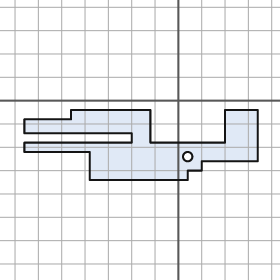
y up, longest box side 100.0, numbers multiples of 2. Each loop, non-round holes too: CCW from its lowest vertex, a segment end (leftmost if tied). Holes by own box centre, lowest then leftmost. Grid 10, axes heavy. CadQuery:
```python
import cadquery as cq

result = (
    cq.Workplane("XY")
    .moveTo(-38.0, -34.0)
    .lineTo(4.0, -34.0)
    .lineTo(4.0, -30.0)
    .lineTo(10.0, -30.0)
    .lineTo(10.0, -26.0)
    .lineTo(34.0, -26.0)
    .lineTo(34.0, -4.0)
    .lineTo(20.0, -4.0)
    .lineTo(20.0, -18.0)
    .lineTo(-12.0, -18.0)
    .lineTo(-12.0, -4.0)
    .lineTo(-46.0, -4.0)
    .lineTo(-46.0, -8.0)
    .lineTo(-66.0, -8.0)
    .lineTo(-66.0, -14.0)
    .lineTo(-20.0, -14.0)
    .lineTo(-20.0, -18.0)
    .lineTo(-66.0, -18.0)
    .lineTo(-66.0, -22.0)
    .lineTo(-38.0, -22.0)
    .close()
    .moveTo(4.0, -24.0)
    .circle(2.0)
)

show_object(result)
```